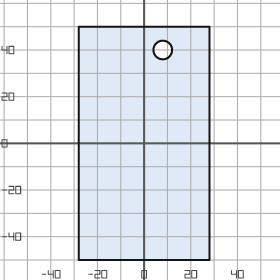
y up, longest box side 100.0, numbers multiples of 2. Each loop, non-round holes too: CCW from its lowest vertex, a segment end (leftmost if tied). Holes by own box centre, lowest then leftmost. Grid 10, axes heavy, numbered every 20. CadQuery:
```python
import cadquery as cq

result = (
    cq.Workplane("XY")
    .moveTo(-28.0, -50.0)
    .lineTo(28.0, -50.0)
    .lineTo(28.0, 50.0)
    .lineTo(-28.0, 50.0)
    .close()
    .moveTo(8.0, 40.0)
    .circle(4.0)
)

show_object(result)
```